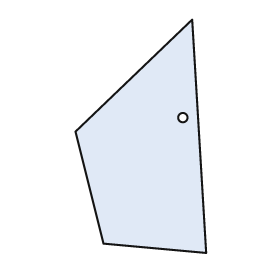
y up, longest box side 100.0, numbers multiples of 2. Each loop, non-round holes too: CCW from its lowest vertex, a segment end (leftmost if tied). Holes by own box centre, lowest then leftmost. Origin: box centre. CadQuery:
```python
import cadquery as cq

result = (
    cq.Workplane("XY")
    .moveTo(28.0, -50.0)
    .lineTo(22.0, 50.0)
    .lineTo(-28.0, 2.0)
    .lineTo(-16.0, -46.0)
    .close()
    .moveTo(18.0, 8.0)
    .circle(2.0)
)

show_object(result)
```